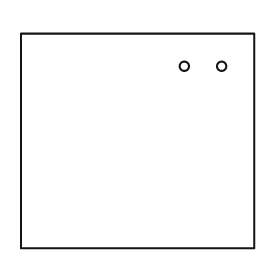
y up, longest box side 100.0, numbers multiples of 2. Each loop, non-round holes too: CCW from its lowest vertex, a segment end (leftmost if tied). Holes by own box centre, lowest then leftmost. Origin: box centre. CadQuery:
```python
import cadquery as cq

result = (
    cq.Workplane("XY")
    .moveTo(-50.0, -46.0)
    .lineTo(50.0, -46.0)
    .lineTo(50.0, 46.0)
    .lineTo(-50.0, 46.0)
    .close()
    .moveTo(20.0, 32.0)
    .circle(2.0)
    .moveTo(36.0, 32.0)
    .circle(2.0)
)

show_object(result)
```